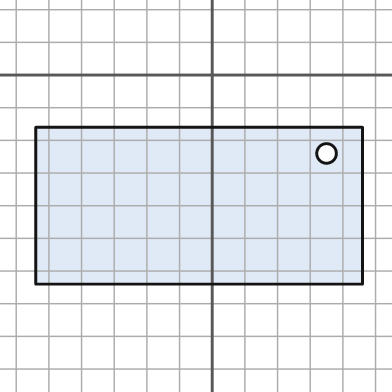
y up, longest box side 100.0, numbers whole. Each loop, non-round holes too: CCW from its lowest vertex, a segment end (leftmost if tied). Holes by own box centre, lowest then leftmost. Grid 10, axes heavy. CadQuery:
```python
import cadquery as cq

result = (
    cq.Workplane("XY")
    .moveTo(-54.0, -64.0)
    .lineTo(46.0, -64.0)
    .lineTo(46.0, -16.0)
    .lineTo(-54.0, -16.0)
    .close()
    .moveTo(35.0, -24.0)
    .circle(3.0)
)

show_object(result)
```